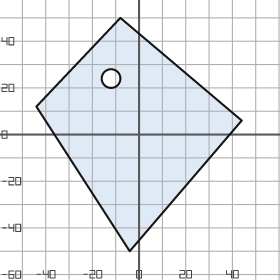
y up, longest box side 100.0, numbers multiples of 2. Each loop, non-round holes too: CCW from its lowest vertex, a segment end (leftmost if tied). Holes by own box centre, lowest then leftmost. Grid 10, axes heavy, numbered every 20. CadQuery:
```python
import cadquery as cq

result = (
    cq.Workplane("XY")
    .moveTo(-4.0, -50.0)
    .lineTo(44.0, 6.0)
    .lineTo(-8.0, 50.0)
    .lineTo(-44.0, 12.0)
    .close()
    .moveTo(-12.0, 24.0)
    .circle(4.0)
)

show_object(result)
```